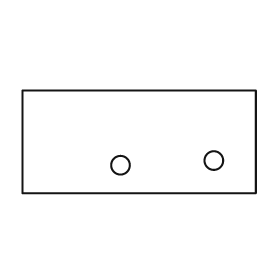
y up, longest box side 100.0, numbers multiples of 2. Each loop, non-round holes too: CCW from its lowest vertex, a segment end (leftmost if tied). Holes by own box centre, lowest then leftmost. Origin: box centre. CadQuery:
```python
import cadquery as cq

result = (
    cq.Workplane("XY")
    .moveTo(-50.0, -22.0)
    .lineTo(50.0, -22.0)
    .lineTo(50.0, 22.0)
    .lineTo(-50.0, 22.0)
    .close()
    .moveTo(-8.0, -10.0)
    .circle(4.0)
    .moveTo(32.0, -8.0)
    .circle(4.0)
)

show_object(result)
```